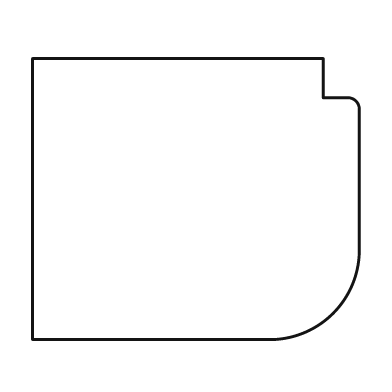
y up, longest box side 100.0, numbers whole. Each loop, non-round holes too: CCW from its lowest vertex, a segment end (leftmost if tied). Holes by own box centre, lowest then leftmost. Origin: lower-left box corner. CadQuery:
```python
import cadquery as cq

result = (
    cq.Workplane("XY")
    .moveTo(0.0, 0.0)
    .lineTo(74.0, 0.0)
    .threePointArc((92.0, 8.0), (100.0, 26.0))
    .lineTo(100.0, 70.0)
    .threePointArc((99.0, 73.0), (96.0, 74.0))
    .lineTo(89.0, 74.0)
    .lineTo(89.0, 86.0)
    .lineTo(0.0, 86.0)
    .close()
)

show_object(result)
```